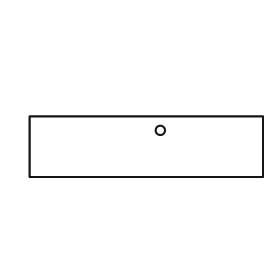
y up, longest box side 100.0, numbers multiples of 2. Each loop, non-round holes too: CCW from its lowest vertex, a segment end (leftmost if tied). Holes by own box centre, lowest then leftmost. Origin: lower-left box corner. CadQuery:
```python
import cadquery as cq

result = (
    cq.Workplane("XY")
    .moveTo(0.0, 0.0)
    .lineTo(100.0, 0.0)
    .lineTo(100.0, 26.0)
    .lineTo(0.0, 26.0)
    .close()
    .moveTo(56.0, 20.0)
    .circle(2.0)
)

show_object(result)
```